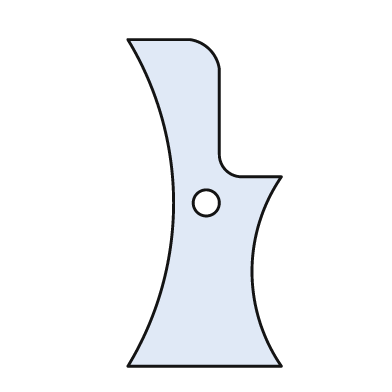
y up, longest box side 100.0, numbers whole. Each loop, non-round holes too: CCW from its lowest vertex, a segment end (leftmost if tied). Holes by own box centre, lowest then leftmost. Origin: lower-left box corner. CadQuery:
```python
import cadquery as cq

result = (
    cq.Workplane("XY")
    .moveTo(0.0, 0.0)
    .lineTo(47.0, 0.0)
    .threePointArc((38.0, 29.0), (47.0, 58.0))
    .lineTo(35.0, 58.0)
    .threePointArc((30.0, 60.0), (28.0, 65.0))
    .lineTo(28.0, 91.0)
    .threePointArc((25.0, 97.0), (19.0, 100.0))
    .lineTo(0.0, 100.0)
    .threePointArc((14.0, 50.0), (0.0, 0.0))
    .close()
    .moveTo(24.0, 50.0)
    .circle(4.0)
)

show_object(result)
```